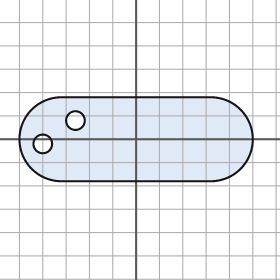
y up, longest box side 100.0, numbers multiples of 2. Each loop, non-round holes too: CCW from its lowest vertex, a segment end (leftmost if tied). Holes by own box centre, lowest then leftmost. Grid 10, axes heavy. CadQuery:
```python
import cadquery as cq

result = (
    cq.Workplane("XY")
    .moveTo(-32.0, -18.0)
    .lineTo(32.0, -18.0)
    .threePointArc((50.0, 0.0), (32.0, 18.0))
    .lineTo(-32.0, 18.0)
    .threePointArc((-50.0, 0.0), (-32.0, -18.0))
    .close()
    .moveTo(-40.0, -2.0)
    .circle(4.0)
    .moveTo(-26.0, 8.0)
    .circle(4.0)
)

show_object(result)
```